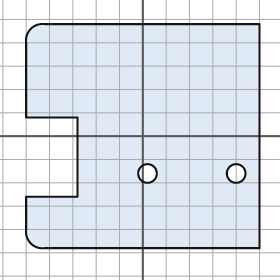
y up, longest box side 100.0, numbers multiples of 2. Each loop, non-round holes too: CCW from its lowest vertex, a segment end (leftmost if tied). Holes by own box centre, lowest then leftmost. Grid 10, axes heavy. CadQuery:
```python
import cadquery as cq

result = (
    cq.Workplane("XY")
    .moveTo(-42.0, -48.0)
    .lineTo(50.0, -48.0)
    .lineTo(50.0, 48.0)
    .lineTo(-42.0, 48.0)
    .threePointArc((-48.0, 46.0), (-50.0, 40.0))
    .lineTo(-50.0, 8.0)
    .lineTo(-28.0, 8.0)
    .lineTo(-28.0, -26.0)
    .lineTo(-50.0, -26.0)
    .lineTo(-50.0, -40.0)
    .threePointArc((-48.0, -46.0), (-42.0, -48.0))
    .close()
    .moveTo(2.0, -16.0)
    .circle(4.0)
    .moveTo(40.0, -16.0)
    .circle(4.0)
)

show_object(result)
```